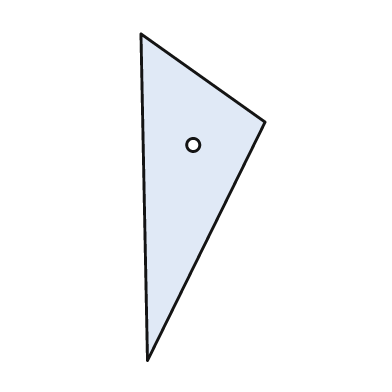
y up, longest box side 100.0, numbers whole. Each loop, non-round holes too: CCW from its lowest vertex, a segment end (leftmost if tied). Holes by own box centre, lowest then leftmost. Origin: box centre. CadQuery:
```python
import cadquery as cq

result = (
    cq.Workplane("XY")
    .moveTo(-17.0, -50.0)
    .lineTo(19.0, 23.0)
    .lineTo(-19.0, 50.0)
    .close()
    .moveTo(-3.0, 16.0)
    .circle(2.0)
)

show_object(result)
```